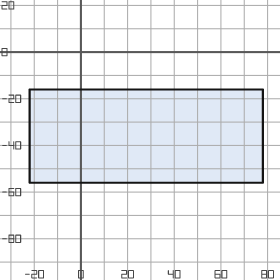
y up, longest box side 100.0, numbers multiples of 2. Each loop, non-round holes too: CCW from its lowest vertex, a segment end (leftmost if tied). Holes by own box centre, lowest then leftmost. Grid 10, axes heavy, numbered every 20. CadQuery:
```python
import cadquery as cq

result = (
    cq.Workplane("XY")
    .moveTo(-22.0, -56.0)
    .lineTo(78.0, -56.0)
    .lineTo(78.0, -16.0)
    .lineTo(-22.0, -16.0)
    .close()
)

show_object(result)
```